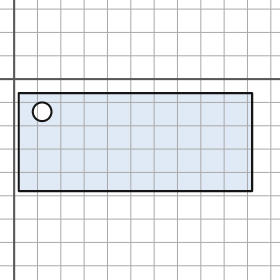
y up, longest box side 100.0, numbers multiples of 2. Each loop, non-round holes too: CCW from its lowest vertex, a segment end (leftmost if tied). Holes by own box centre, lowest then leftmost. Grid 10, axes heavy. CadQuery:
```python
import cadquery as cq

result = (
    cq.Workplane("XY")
    .moveTo(2.0, -48.0)
    .lineTo(102.0, -48.0)
    .lineTo(102.0, -6.0)
    .lineTo(2.0, -6.0)
    .close()
    .moveTo(12.0, -14.0)
    .circle(4.0)
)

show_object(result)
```